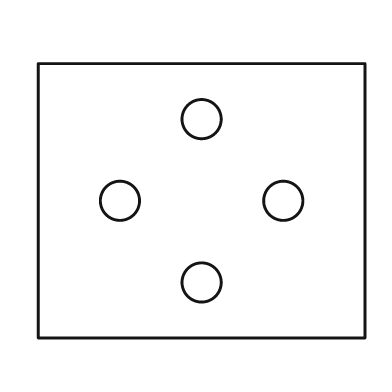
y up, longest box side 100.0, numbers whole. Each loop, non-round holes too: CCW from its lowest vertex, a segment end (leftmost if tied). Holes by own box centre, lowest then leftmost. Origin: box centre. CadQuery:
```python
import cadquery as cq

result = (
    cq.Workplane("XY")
    .moveTo(-50.0, -42.0)
    .lineTo(50.0, -42.0)
    .lineTo(50.0, 42.0)
    .lineTo(-50.0, 42.0)
    .close()
    .moveTo(0.0, -25.0)
    .circle(6.0)
    .moveTo(-25.0, 0.0)
    .circle(6.0)
    .moveTo(25.0, 0.0)
    .circle(6.0)
    .moveTo(0.0, 25.0)
    .circle(6.0)
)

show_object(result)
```